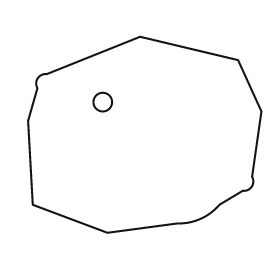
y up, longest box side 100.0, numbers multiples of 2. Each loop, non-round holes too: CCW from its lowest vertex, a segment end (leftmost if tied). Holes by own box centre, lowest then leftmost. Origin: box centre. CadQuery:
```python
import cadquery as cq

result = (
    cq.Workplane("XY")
    .moveTo(-16.0, -42.0)
    .lineTo(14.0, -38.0)
    .threePointArc((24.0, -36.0), (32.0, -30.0))
    .lineTo(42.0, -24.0)
    .threePointArc((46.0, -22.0), (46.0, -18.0))
    .lineTo(50.0, 10.0)
    .lineTo(40.0, 32.0)
    .lineTo(-2.0, 42.0)
    .lineTo(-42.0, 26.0)
    .threePointArc((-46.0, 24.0), (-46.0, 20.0))
    .lineTo(-50.0, 6.0)
    .lineTo(-48.0, -30.0)
    .close()
    .moveTo(-18.0, 14.0)
    .circle(4.0)
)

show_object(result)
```